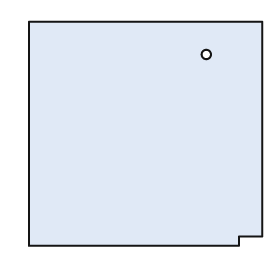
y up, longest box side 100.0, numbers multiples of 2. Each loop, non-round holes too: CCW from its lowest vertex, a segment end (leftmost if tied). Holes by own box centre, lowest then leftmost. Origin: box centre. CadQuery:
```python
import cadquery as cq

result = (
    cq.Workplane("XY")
    .moveTo(-50.0, -48.0)
    .lineTo(40.0, -48.0)
    .lineTo(40.0, -44.0)
    .lineTo(50.0, -44.0)
    .lineTo(50.0, 48.0)
    .lineTo(-50.0, 48.0)
    .close()
    .moveTo(26.0, 34.0)
    .circle(2.0)
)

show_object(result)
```